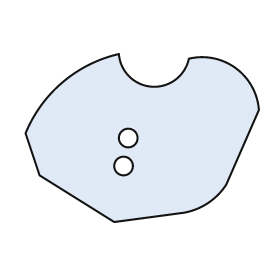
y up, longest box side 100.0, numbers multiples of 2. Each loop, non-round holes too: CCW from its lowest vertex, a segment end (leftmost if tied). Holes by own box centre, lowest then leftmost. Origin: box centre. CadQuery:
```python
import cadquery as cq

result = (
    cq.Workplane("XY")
    .moveTo(-12.0, -36.0)
    .lineTo(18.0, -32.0)
    .threePointArc((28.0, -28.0), (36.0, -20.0))
    .lineTo(50.0, 12.0)
    .threePointArc((40.0, 30.0), (20.0, 34.0))
    .threePointArc((4.0, 22.0), (-10.0, 36.0))
    .threePointArc((-34.0, 24.0), (-50.0, 2.0))
    .lineTo(-44.0, -16.0)
    .close()
    .moveTo(-8.0, -12.0)
    .circle(4.0)
    .moveTo(-6.0, 0.0)
    .circle(4.0)
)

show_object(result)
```